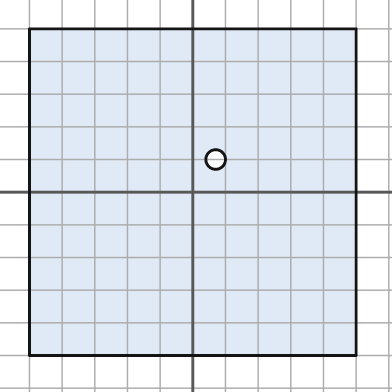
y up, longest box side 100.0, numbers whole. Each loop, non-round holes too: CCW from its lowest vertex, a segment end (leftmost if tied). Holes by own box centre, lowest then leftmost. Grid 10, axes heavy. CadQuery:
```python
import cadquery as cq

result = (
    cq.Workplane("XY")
    .moveTo(-50.0, -50.0)
    .lineTo(50.0, -50.0)
    .lineTo(50.0, 50.0)
    .lineTo(-50.0, 50.0)
    .close()
    .moveTo(7.0, 10.0)
    .circle(3.0)
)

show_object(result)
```